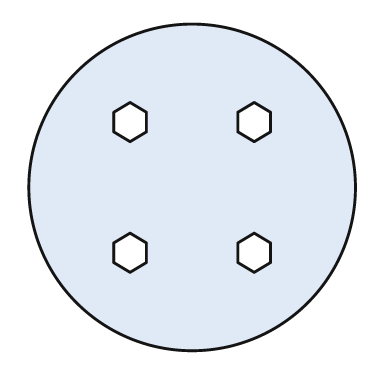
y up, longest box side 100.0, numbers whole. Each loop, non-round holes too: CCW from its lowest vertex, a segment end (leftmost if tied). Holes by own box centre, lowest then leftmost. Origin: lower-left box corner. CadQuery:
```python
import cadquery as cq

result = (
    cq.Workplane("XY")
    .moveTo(50.0, 50.0)
    .circle(50.0)
    .moveTo(31.0, 24.0)
    .lineTo(36.0, 27.0)
    .lineTo(36.0, 33.0)
    .lineTo(31.0, 36.0)
    .lineTo(26.0, 33.0)
    .lineTo(26.0, 27.0)
    .close()
    .moveTo(69.0, 24.0)
    .lineTo(74.0, 27.0)
    .lineTo(74.0, 33.0)
    .lineTo(69.0, 36.0)
    .lineTo(64.0, 33.0)
    .lineTo(64.0, 27.0)
    .close()
    .moveTo(31.0, 64.0)
    .lineTo(36.0, 67.0)
    .lineTo(36.0, 73.0)
    .lineTo(31.0, 76.0)
    .lineTo(26.0, 73.0)
    .lineTo(26.0, 67.0)
    .close()
    .moveTo(69.0, 64.0)
    .lineTo(74.0, 67.0)
    .lineTo(74.0, 73.0)
    .lineTo(69.0, 76.0)
    .lineTo(64.0, 73.0)
    .lineTo(64.0, 67.0)
    .close()
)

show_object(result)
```